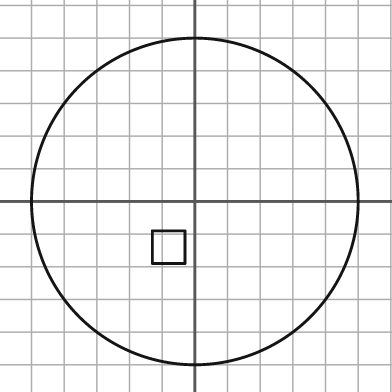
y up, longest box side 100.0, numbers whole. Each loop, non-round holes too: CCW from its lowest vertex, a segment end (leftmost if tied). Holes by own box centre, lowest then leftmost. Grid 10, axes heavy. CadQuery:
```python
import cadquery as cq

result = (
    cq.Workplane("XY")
    .moveTo(0.0, 0.0)
    .circle(50.0)
    .moveTo(-13.0, -19.0)
    .lineTo(-3.0, -19.0)
    .lineTo(-3.0, -9.0)
    .lineTo(-13.0, -9.0)
    .close()
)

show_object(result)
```